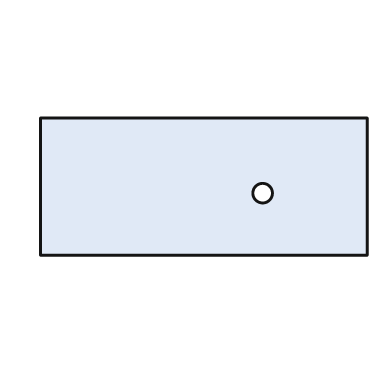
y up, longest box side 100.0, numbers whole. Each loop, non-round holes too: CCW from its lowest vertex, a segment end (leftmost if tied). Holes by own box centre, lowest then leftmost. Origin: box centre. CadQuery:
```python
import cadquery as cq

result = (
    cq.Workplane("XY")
    .moveTo(-50.0, -21.0)
    .lineTo(50.0, -21.0)
    .lineTo(50.0, 21.0)
    .lineTo(-50.0, 21.0)
    .close()
    .moveTo(18.0, -2.0)
    .circle(3.0)
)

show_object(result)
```